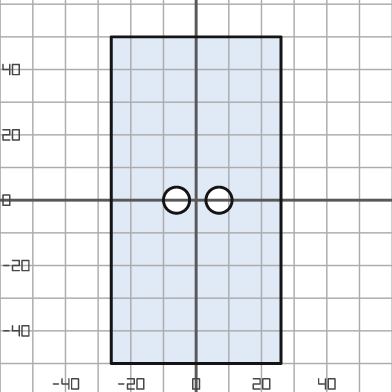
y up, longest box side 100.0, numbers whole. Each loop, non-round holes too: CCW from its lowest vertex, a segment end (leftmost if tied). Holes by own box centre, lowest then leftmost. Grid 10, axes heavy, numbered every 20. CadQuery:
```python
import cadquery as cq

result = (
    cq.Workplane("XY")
    .moveTo(-26.0, -50.0)
    .lineTo(26.0, -50.0)
    .lineTo(26.0, 50.0)
    .lineTo(-26.0, 50.0)
    .close()
    .moveTo(-6.0, 0.0)
    .circle(4.0)
    .moveTo(7.0, 0.0)
    .circle(4.0)
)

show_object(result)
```